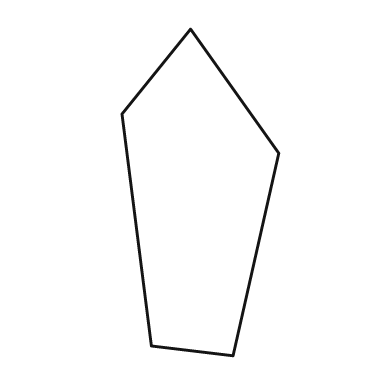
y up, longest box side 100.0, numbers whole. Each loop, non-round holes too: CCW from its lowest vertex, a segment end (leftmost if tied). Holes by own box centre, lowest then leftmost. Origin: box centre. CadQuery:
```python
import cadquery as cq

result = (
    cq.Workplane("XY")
    .moveTo(10.0, -50.0)
    .lineTo(24.0, 12.0)
    .lineTo(-3.0, 50.0)
    .lineTo(-24.0, 24.0)
    .lineTo(-15.0, -47.0)
    .close()
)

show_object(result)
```